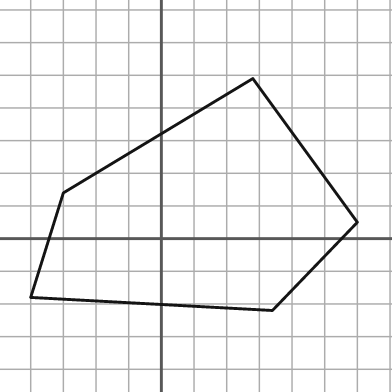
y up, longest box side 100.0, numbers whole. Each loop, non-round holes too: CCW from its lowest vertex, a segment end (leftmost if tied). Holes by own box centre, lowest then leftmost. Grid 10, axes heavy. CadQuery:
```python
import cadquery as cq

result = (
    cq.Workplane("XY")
    .moveTo(34.0, -22.0)
    .lineTo(60.0, 5.0)
    .lineTo(28.0, 49.0)
    .lineTo(-30.0, 14.0)
    .lineTo(-40.0, -18.0)
    .close()
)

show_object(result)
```